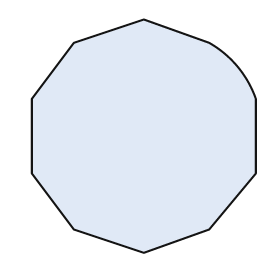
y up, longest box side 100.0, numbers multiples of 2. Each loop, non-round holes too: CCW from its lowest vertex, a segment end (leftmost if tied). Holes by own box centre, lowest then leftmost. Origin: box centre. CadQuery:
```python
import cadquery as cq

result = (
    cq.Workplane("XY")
    .moveTo(0.0, -50.0)
    .lineTo(28.0, -40.0)
    .lineTo(48.0, -16.0)
    .lineTo(48.0, 16.0)
    .threePointArc((40.0, 30.0), (28.0, 40.0))
    .lineTo(0.0, 50.0)
    .lineTo(-30.0, 40.0)
    .lineTo(-48.0, 16.0)
    .lineTo(-48.0, -16.0)
    .lineTo(-30.0, -40.0)
    .close()
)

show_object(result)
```